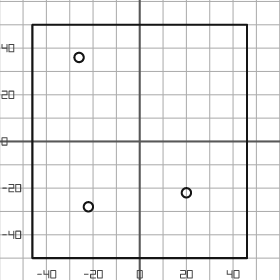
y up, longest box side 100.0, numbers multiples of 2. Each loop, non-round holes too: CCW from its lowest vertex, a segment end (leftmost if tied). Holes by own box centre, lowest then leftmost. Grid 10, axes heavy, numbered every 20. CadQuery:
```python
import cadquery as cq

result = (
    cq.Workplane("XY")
    .moveTo(-46.0, -50.0)
    .lineTo(46.0, -50.0)
    .lineTo(46.0, 50.0)
    .lineTo(-46.0, 50.0)
    .close()
    .moveTo(-22.0, -28.0)
    .circle(2.0)
    .moveTo(20.0, -22.0)
    .circle(2.0)
    .moveTo(-26.0, 36.0)
    .circle(2.0)
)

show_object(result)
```